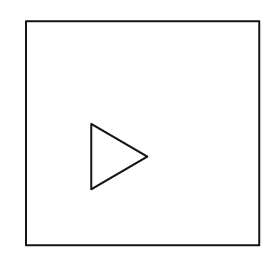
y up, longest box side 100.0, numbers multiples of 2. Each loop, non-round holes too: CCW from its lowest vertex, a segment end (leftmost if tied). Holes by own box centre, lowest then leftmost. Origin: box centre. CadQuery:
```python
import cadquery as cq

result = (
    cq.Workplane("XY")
    .moveTo(-50.0, -48.0)
    .lineTo(50.0, -48.0)
    .lineTo(50.0, 48.0)
    .lineTo(-50.0, 48.0)
    .close()
    .moveTo(-22.0, -24.0)
    .lineTo(2.0, -10.0)
    .lineTo(-22.0, 4.0)
    .close()
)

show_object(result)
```